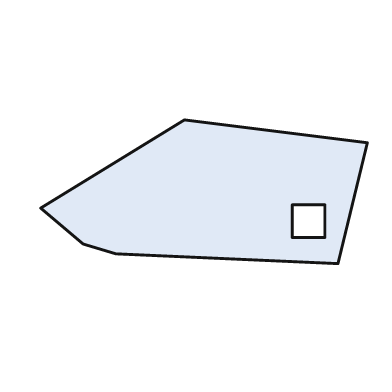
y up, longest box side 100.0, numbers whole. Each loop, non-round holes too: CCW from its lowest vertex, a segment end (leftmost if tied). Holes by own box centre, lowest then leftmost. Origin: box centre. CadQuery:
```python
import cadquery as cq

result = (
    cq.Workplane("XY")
    .moveTo(41.0, -22.0)
    .lineTo(50.0, 15.0)
    .lineTo(-6.0, 22.0)
    .lineTo(-50.0, -5.0)
    .lineTo(-37.0, -16.0)
    .lineTo(-27.0, -19.0)
    .close()
    .moveTo(27.0, -14.0)
    .lineTo(37.0, -14.0)
    .lineTo(37.0, -4.0)
    .lineTo(27.0, -4.0)
    .close()
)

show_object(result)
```